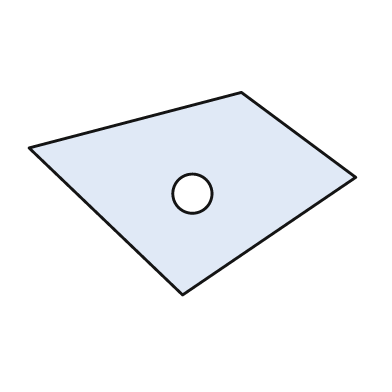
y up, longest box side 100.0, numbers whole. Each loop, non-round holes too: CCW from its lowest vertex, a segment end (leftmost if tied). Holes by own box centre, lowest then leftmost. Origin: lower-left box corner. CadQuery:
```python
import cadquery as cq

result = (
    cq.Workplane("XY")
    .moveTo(47.0, 0.0)
    .lineTo(100.0, 36.0)
    .lineTo(65.0, 62.0)
    .lineTo(0.0, 45.0)
    .close()
    .moveTo(50.0, 31.0)
    .circle(6.0)
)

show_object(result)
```